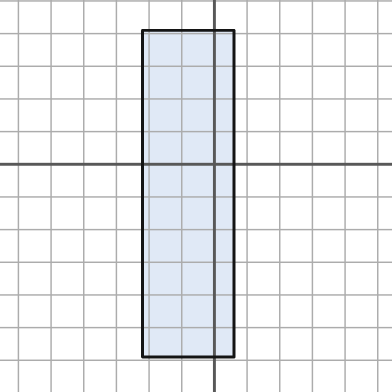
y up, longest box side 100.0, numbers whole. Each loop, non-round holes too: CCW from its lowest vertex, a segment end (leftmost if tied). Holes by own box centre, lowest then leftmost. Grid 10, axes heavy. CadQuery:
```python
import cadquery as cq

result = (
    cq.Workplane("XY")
    .moveTo(-22.0, -59.0)
    .lineTo(6.0, -59.0)
    .lineTo(6.0, 41.0)
    .lineTo(-22.0, 41.0)
    .close()
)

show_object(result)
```